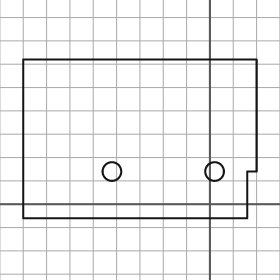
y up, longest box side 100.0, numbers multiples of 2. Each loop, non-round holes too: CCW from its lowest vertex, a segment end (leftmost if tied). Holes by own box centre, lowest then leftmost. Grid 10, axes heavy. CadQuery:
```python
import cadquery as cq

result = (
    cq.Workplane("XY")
    .moveTo(-80.0, -6.0)
    .lineTo(16.0, -6.0)
    .lineTo(16.0, 14.0)
    .lineTo(20.0, 14.0)
    .lineTo(20.0, 62.0)
    .lineTo(-80.0, 62.0)
    .close()
    .moveTo(-42.0, 14.0)
    .circle(4.0)
    .moveTo(2.0, 14.0)
    .circle(4.0)
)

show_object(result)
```